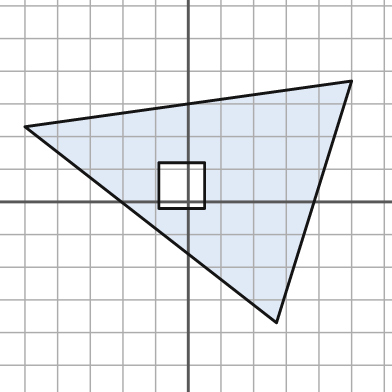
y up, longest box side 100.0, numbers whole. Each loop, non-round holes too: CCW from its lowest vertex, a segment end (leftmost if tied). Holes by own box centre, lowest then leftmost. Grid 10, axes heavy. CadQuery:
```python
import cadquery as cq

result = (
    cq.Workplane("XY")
    .moveTo(27.0, -37.0)
    .lineTo(50.0, 37.0)
    .lineTo(-50.0, 23.0)
    .close()
    .moveTo(-9.0, -2.0)
    .lineTo(5.0, -2.0)
    .lineTo(5.0, 12.0)
    .lineTo(-9.0, 12.0)
    .close()
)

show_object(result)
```